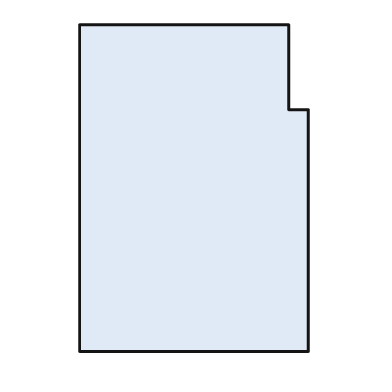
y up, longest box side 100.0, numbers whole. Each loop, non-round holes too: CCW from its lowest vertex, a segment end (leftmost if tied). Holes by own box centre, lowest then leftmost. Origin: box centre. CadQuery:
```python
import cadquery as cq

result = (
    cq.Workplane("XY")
    .moveTo(-35.0, -50.0)
    .lineTo(35.0, -50.0)
    .lineTo(35.0, 24.0)
    .lineTo(29.0, 24.0)
    .lineTo(29.0, 50.0)
    .lineTo(-35.0, 50.0)
    .close()
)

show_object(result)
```